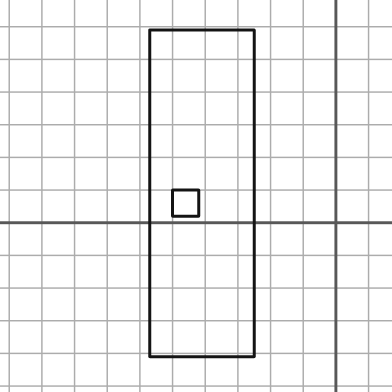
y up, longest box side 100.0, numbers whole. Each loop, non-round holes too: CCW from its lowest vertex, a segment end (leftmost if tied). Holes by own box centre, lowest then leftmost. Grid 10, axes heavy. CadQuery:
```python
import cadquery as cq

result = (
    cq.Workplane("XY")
    .moveTo(-57.0, -41.0)
    .lineTo(-25.0, -41.0)
    .lineTo(-25.0, 59.0)
    .lineTo(-57.0, 59.0)
    .close()
    .moveTo(-50.0, 2.0)
    .lineTo(-42.0, 2.0)
    .lineTo(-42.0, 10.0)
    .lineTo(-50.0, 10.0)
    .close()
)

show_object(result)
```